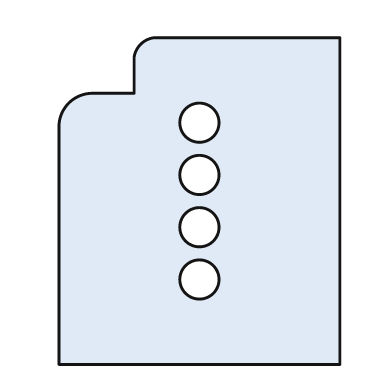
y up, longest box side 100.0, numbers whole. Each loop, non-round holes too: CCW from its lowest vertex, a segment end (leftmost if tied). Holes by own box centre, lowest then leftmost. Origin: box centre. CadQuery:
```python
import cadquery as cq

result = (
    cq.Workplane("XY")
    .moveTo(-43.0, -50.0)
    .lineTo(43.0, -50.0)
    .lineTo(43.0, 50.0)
    .lineTo(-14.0, 50.0)
    .threePointArc((-18.0, 48.0), (-20.0, 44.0))
    .lineTo(-20.0, 33.0)
    .lineTo(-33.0, 33.0)
    .threePointArc((-40.0, 30.0), (-43.0, 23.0))
    .close()
    .moveTo(0.0, -24.0)
    .circle(6.0)
    .moveTo(0.0, -8.0)
    .circle(6.0)
    .moveTo(0.0, 8.0)
    .circle(6.0)
    .moveTo(0.0, 24.0)
    .circle(6.0)
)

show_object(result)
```